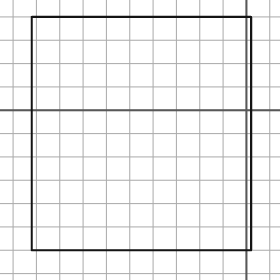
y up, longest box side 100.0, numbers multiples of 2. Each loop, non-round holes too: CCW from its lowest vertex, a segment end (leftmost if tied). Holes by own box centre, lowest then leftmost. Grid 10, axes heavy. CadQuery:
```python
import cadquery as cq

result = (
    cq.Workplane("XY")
    .moveTo(-92.0, -60.0)
    .lineTo(2.0, -60.0)
    .lineTo(2.0, 40.0)
    .lineTo(-92.0, 40.0)
    .close()
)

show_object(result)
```